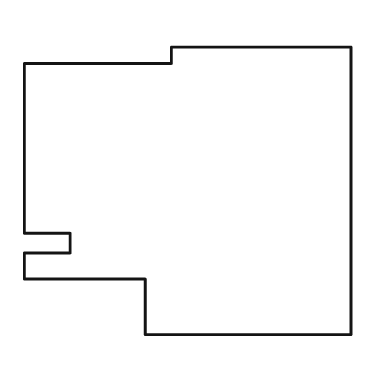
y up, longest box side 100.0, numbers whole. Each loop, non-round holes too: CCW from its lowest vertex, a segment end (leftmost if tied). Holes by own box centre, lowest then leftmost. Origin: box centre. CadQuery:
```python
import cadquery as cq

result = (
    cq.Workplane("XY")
    .moveTo(-13.0, -44.0)
    .lineTo(50.0, -44.0)
    .lineTo(50.0, 44.0)
    .lineTo(-5.0, 44.0)
    .lineTo(-5.0, 39.0)
    .lineTo(-50.0, 39.0)
    .lineTo(-50.0, -13.0)
    .lineTo(-36.0, -13.0)
    .lineTo(-36.0, -19.0)
    .lineTo(-50.0, -19.0)
    .lineTo(-50.0, -27.0)
    .lineTo(-13.0, -27.0)
    .close()
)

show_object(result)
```